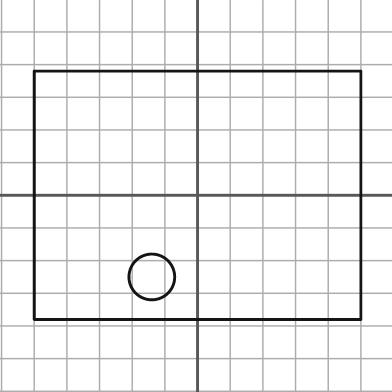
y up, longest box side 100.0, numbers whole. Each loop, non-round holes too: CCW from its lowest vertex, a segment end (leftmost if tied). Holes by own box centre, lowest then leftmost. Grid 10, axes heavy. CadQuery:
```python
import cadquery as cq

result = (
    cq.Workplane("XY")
    .moveTo(-50.0, -38.0)
    .lineTo(50.0, -38.0)
    .lineTo(50.0, 38.0)
    .lineTo(-50.0, 38.0)
    .close()
    .moveTo(-14.0, -25.0)
    .circle(7.0)
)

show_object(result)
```